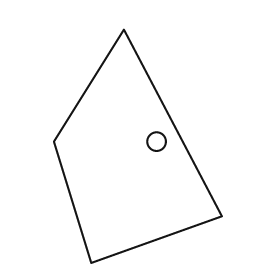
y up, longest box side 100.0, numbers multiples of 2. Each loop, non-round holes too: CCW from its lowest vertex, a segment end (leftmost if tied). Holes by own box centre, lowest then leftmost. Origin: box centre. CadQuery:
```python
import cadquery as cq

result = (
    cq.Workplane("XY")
    .moveTo(-20.0, -50.0)
    .lineTo(36.0, -30.0)
    .lineTo(-6.0, 50.0)
    .lineTo(-36.0, 2.0)
    .close()
    .moveTo(8.0, 2.0)
    .circle(4.0)
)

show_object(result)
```